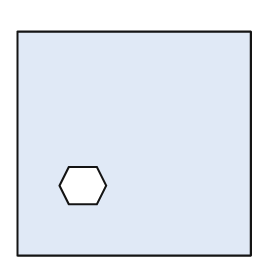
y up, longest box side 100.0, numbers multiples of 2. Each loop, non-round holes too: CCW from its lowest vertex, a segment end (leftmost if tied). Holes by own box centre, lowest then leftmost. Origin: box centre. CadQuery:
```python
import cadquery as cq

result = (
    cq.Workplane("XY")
    .moveTo(-50.0, -48.0)
    .lineTo(50.0, -48.0)
    .lineTo(50.0, 48.0)
    .lineTo(-50.0, 48.0)
    .close()
    .moveTo(-28.0, -26.0)
    .lineTo(-16.0, -26.0)
    .lineTo(-12.0, -18.0)
    .lineTo(-16.0, -10.0)
    .lineTo(-28.0, -10.0)
    .lineTo(-32.0, -18.0)
    .close()
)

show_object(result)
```